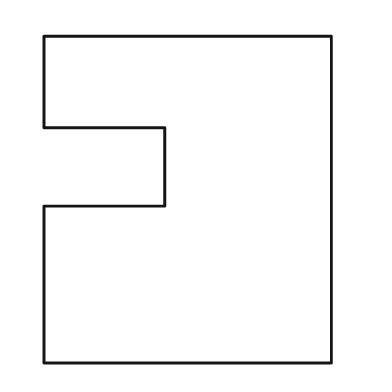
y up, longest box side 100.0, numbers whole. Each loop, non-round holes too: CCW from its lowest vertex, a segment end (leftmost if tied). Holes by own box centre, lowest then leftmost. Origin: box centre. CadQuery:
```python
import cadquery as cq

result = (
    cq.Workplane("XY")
    .moveTo(-44.0, -50.0)
    .lineTo(44.0, -50.0)
    .lineTo(44.0, 50.0)
    .lineTo(-44.0, 50.0)
    .lineTo(-44.0, 22.0)
    .lineTo(-7.0, 22.0)
    .lineTo(-7.0, -2.0)
    .lineTo(-44.0, -2.0)
    .close()
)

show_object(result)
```